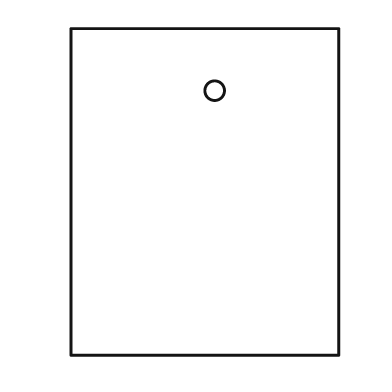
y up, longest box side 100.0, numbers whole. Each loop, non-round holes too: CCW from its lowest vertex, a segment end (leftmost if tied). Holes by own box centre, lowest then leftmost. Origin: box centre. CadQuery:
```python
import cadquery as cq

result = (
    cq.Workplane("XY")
    .moveTo(-41.0, -50.0)
    .lineTo(41.0, -50.0)
    .lineTo(41.0, 50.0)
    .lineTo(-41.0, 50.0)
    .close()
    .moveTo(3.0, 31.0)
    .circle(3.0)
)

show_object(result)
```